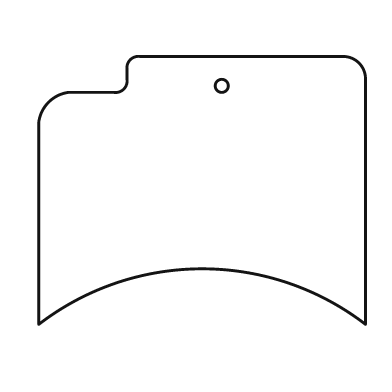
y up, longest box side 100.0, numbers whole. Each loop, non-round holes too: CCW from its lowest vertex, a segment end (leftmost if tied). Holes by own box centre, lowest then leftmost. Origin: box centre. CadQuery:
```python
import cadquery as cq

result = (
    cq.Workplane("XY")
    .moveTo(-50.0, -41.0)
    .threePointArc((0.0, -24.0), (50.0, -41.0))
    .lineTo(50.0, 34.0)
    .threePointArc((48.0, 39.0), (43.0, 41.0))
    .lineTo(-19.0, 41.0)
    .threePointArc((-22.0, 40.0), (-23.0, 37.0))
    .lineTo(-23.0, 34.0)
    .threePointArc((-24.0, 31.0), (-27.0, 30.0))
    .lineTo(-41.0, 30.0)
    .threePointArc((-47.0, 27.0), (-50.0, 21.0))
    .close()
    .moveTo(6.0, 32.0)
    .circle(2.0)
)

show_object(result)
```